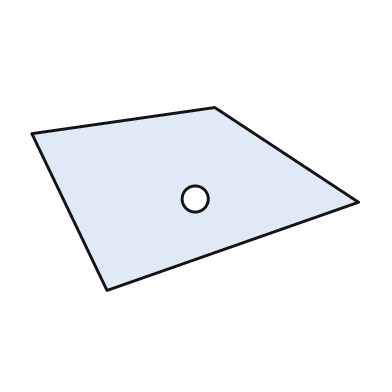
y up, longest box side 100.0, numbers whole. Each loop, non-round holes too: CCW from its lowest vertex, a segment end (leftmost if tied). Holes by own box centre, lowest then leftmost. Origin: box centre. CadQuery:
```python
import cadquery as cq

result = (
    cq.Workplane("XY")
    .moveTo(-27.0, -28.0)
    .lineTo(50.0, -1.0)
    .lineTo(6.0, 28.0)
    .lineTo(-50.0, 20.0)
    .close()
    .moveTo(0.0, 0.0)
    .circle(4.0)
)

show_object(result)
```